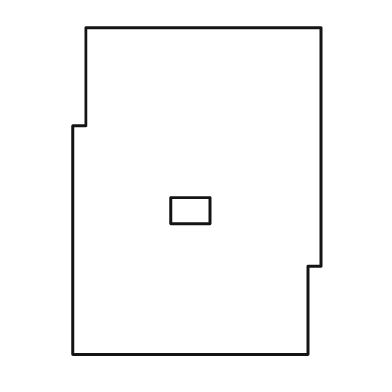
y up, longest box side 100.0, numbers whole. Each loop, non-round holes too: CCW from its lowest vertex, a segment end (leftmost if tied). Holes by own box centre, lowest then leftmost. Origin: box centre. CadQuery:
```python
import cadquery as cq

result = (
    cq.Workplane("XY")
    .moveTo(-38.0, -50.0)
    .lineTo(34.0, -50.0)
    .lineTo(34.0, -23.0)
    .lineTo(38.0, -23.0)
    .lineTo(38.0, 50.0)
    .lineTo(-34.0, 50.0)
    .lineTo(-34.0, 20.0)
    .lineTo(-38.0, 20.0)
    .close()
    .moveTo(-8.0, -10.0)
    .lineTo(4.0, -10.0)
    .lineTo(4.0, -2.0)
    .lineTo(-8.0, -2.0)
    .close()
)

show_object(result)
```